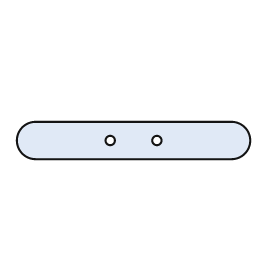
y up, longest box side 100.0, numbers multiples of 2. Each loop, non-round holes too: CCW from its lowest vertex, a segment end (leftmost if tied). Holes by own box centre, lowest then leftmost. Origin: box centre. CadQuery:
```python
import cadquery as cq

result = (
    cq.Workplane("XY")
    .moveTo(-42.0, -8.0)
    .lineTo(42.0, -8.0)
    .threePointArc((50.0, 0.0), (42.0, 8.0))
    .lineTo(-42.0, 8.0)
    .threePointArc((-50.0, 0.0), (-42.0, -8.0))
    .close()
    .moveTo(-10.0, 0.0)
    .circle(2.0)
    .moveTo(10.0, 0.0)
    .circle(2.0)
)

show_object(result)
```